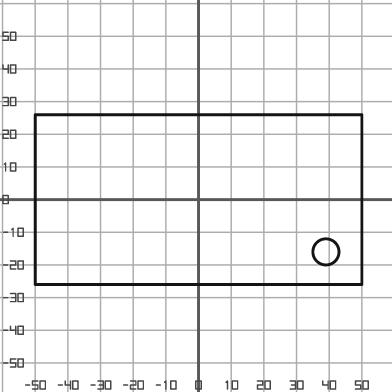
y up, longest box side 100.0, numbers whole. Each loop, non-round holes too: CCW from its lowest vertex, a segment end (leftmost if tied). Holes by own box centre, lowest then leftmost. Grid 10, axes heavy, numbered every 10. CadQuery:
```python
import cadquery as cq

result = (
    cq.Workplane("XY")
    .moveTo(-50.0, -26.0)
    .lineTo(50.0, -26.0)
    .lineTo(50.0, 26.0)
    .lineTo(-50.0, 26.0)
    .close()
    .moveTo(39.0, -16.0)
    .circle(4.0)
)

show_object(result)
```